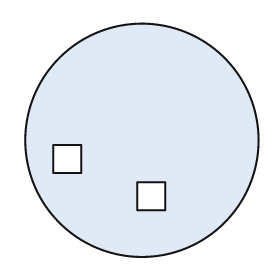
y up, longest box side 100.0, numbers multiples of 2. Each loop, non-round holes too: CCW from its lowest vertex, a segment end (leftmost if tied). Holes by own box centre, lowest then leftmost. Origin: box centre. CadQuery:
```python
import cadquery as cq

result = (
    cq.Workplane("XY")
    .moveTo(0.0, 0.0)
    .circle(50.0)
    .moveTo(-2.0, -30.0)
    .lineTo(10.0, -30.0)
    .lineTo(10.0, -18.0)
    .lineTo(-2.0, -18.0)
    .close()
    .moveTo(-38.0, -14.0)
    .lineTo(-26.0, -14.0)
    .lineTo(-26.0, -2.0)
    .lineTo(-38.0, -2.0)
    .close()
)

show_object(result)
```